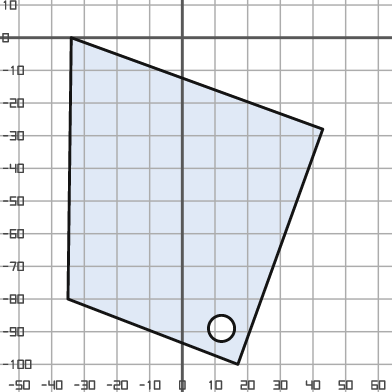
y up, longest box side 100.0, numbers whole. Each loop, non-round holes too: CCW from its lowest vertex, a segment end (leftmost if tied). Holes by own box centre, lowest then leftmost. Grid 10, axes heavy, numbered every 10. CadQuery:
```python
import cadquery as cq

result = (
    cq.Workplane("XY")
    .moveTo(17.0, -100.0)
    .lineTo(43.0, -28.0)
    .lineTo(-34.0, 0.0)
    .lineTo(-35.0, -80.0)
    .close()
    .moveTo(12.0, -89.0)
    .circle(4.0)
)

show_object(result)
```